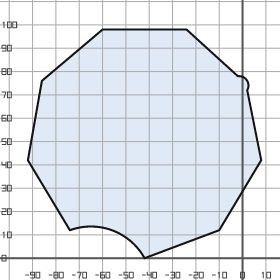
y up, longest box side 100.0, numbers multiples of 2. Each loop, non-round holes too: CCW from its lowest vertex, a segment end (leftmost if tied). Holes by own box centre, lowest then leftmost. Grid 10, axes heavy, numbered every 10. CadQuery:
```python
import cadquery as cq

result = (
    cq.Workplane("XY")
    .moveTo(-42.0, 0.0)
    .lineTo(-10.0, 12.0)
    .lineTo(8.0, 42.0)
    .lineTo(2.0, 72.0)
    .threePointArc((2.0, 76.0), (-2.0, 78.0))
    .lineTo(-24.0, 98.0)
    .lineTo(-60.0, 98.0)
    .lineTo(-86.0, 76.0)
    .lineTo(-92.0, 42.0)
    .lineTo(-74.0, 12.0)
    .threePointArc((-56.0, 12.0), (-42.0, 0.0))
    .close()
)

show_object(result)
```